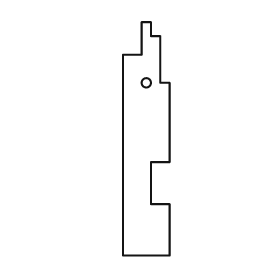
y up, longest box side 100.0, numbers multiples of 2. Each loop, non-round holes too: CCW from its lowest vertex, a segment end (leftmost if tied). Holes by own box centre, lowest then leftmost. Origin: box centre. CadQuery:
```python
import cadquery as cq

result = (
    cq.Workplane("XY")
    .moveTo(-10.0, -50.0)
    .lineTo(10.0, -50.0)
    .lineTo(10.0, -28.0)
    .lineTo(2.0, -28.0)
    .lineTo(2.0, -10.0)
    .lineTo(10.0, -10.0)
    .lineTo(10.0, 24.0)
    .lineTo(6.0, 24.0)
    .lineTo(6.0, 44.0)
    .lineTo(2.0, 44.0)
    .lineTo(2.0, 50.0)
    .lineTo(-2.0, 50.0)
    .lineTo(-2.0, 36.0)
    .lineTo(-10.0, 36.0)
    .close()
    .moveTo(0.0, 24.0)
    .circle(2.0)
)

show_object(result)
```